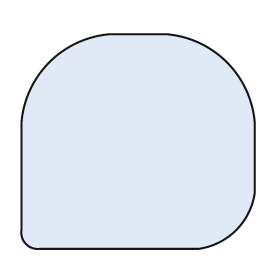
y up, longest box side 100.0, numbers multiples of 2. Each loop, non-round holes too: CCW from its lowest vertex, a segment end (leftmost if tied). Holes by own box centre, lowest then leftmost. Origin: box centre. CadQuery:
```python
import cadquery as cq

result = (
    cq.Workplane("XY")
    .moveTo(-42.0, -46.0)
    .lineTo(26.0, -46.0)
    .threePointArc((42.0, -38.0), (50.0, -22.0))
    .lineTo(50.0, 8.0)
    .threePointArc((38.0, 34.0), (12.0, 46.0))
    .lineTo(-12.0, 46.0)
    .threePointArc((-38.0, 34.0), (-50.0, 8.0))
    .lineTo(-50.0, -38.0)
    .threePointArc((-48.0, -44.0), (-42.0, -46.0))
    .close()
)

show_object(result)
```